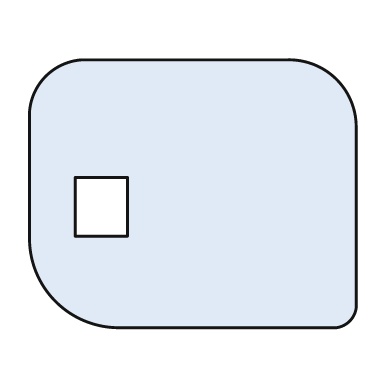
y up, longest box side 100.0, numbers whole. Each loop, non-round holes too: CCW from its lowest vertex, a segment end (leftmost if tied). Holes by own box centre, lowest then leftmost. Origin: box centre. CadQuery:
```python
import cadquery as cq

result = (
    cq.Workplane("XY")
    .moveTo(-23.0, -41.0)
    .lineTo(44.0, -41.0)
    .threePointArc((48.0, -39.0), (50.0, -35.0))
    .lineTo(50.0, 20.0)
    .threePointArc((44.0, 35.0), (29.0, 41.0))
    .lineTo(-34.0, 41.0)
    .threePointArc((-45.0, 36.0), (-50.0, 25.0))
    .lineTo(-50.0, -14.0)
    .threePointArc((-42.0, -33.0), (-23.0, -41.0))
    .close()
    .moveTo(-36.0, -13.0)
    .lineTo(-20.0, -13.0)
    .lineTo(-20.0, 5.0)
    .lineTo(-36.0, 5.0)
    .close()
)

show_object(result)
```